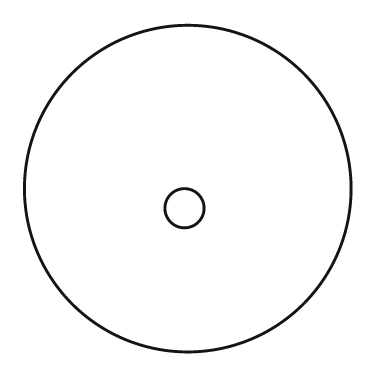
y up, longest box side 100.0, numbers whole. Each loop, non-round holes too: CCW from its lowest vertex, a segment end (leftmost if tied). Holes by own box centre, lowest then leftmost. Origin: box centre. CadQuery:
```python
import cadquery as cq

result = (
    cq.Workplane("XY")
    .moveTo(0.0, 0.0)
    .circle(50.0)
    .moveTo(-1.0, -6.0)
    .circle(6.0)
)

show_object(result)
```